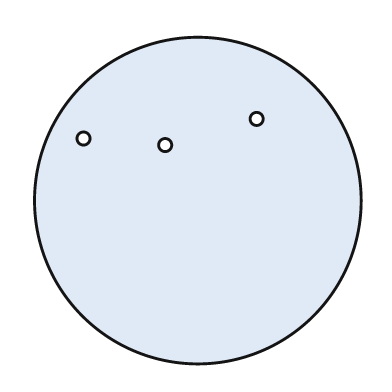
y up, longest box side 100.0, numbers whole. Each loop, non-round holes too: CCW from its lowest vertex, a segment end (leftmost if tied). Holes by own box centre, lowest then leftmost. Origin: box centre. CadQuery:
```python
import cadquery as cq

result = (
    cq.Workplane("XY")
    .moveTo(0.0, 0.0)
    .circle(50.0)
    .moveTo(-10.0, 17.0)
    .circle(2.0)
    .moveTo(-35.0, 19.0)
    .circle(2.0)
    .moveTo(18.0, 25.0)
    .circle(2.0)
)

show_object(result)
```